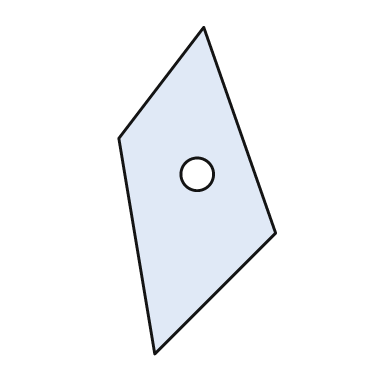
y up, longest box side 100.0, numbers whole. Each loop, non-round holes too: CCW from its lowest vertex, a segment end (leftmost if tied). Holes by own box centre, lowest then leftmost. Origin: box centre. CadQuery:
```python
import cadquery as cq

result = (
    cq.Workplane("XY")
    .moveTo(-13.0, -50.0)
    .lineTo(24.0, -13.0)
    .lineTo(2.0, 50.0)
    .lineTo(-24.0, 16.0)
    .close()
    .moveTo(0.0, 5.0)
    .circle(5.0)
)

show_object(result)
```